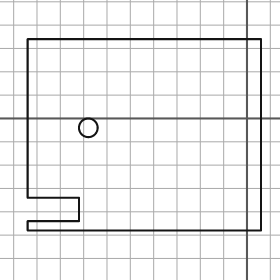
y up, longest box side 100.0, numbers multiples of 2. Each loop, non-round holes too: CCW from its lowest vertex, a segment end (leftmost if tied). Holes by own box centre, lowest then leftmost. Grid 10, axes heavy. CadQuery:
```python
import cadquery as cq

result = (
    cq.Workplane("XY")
    .moveTo(-94.0, -48.0)
    .lineTo(6.0, -48.0)
    .lineTo(6.0, 34.0)
    .lineTo(-94.0, 34.0)
    .lineTo(-94.0, -34.0)
    .lineTo(-72.0, -34.0)
    .lineTo(-72.0, -44.0)
    .lineTo(-94.0, -44.0)
    .close()
    .moveTo(-68.0, -4.0)
    .circle(4.0)
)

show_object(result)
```